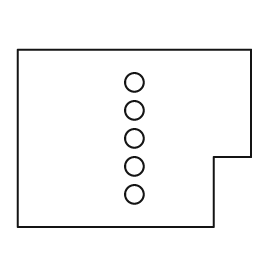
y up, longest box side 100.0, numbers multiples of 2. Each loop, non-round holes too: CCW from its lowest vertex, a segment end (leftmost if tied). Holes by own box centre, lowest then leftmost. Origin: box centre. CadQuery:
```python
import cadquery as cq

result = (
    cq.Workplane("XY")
    .moveTo(-50.0, -38.0)
    .lineTo(34.0, -38.0)
    .lineTo(34.0, -8.0)
    .lineTo(50.0, -8.0)
    .lineTo(50.0, 38.0)
    .lineTo(-50.0, 38.0)
    .close()
    .moveTo(0.0, -24.0)
    .circle(4.0)
    .moveTo(0.0, -12.0)
    .circle(4.0)
    .moveTo(0.0, 0.0)
    .circle(4.0)
    .moveTo(0.0, 12.0)
    .circle(4.0)
    .moveTo(0.0, 24.0)
    .circle(4.0)
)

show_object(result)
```